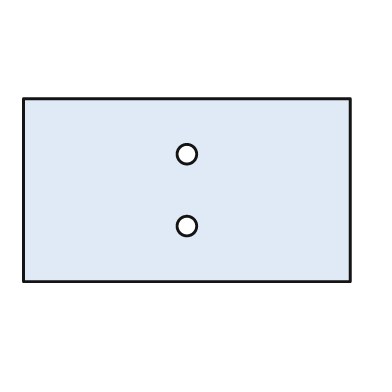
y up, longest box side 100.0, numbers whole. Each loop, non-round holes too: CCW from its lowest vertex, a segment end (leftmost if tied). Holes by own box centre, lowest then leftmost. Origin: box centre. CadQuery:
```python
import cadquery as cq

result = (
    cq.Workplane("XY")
    .moveTo(-50.0, -28.0)
    .lineTo(50.0, -28.0)
    .lineTo(50.0, 28.0)
    .lineTo(-50.0, 28.0)
    .close()
    .moveTo(0.0, -11.0)
    .circle(3.0)
    .moveTo(0.0, 11.0)
    .circle(3.0)
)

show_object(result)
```